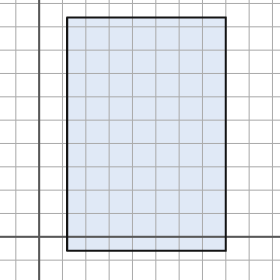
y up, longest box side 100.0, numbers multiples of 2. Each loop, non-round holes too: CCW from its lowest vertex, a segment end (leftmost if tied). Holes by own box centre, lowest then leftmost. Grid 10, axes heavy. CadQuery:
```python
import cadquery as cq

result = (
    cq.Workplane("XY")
    .moveTo(12.0, -6.0)
    .lineTo(80.0, -6.0)
    .lineTo(80.0, 94.0)
    .lineTo(12.0, 94.0)
    .close()
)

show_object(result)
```